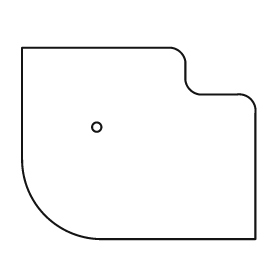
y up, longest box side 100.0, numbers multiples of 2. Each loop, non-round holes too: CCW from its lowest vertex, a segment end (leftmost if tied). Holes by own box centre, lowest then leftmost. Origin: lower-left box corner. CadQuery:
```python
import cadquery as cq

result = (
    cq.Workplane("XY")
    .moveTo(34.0, 0.0)
    .lineTo(100.0, 0.0)
    .lineTo(100.0, 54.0)
    .threePointArc((98.0, 60.0), (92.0, 62.0))
    .lineTo(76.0, 62.0)
    .threePointArc((72.0, 64.0), (70.0, 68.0))
    .lineTo(70.0, 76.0)
    .threePointArc((68.0, 80.0), (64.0, 82.0))
    .lineTo(0.0, 82.0)
    .lineTo(0.0, 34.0)
    .threePointArc((10.0, 10.0), (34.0, 0.0))
    .close()
    .moveTo(32.0, 48.0)
    .circle(2.0)
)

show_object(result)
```